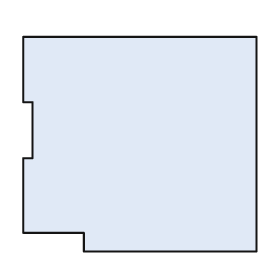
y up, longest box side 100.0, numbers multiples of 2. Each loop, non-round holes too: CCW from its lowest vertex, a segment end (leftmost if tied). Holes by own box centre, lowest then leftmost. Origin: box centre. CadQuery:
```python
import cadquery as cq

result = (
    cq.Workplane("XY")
    .moveTo(-24.0, -46.0)
    .lineTo(50.0, -46.0)
    .lineTo(50.0, 46.0)
    .lineTo(-50.0, 46.0)
    .lineTo(-50.0, 18.0)
    .lineTo(-46.0, 18.0)
    .lineTo(-46.0, -6.0)
    .lineTo(-50.0, -6.0)
    .lineTo(-50.0, -38.0)
    .lineTo(-24.0, -38.0)
    .close()
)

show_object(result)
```